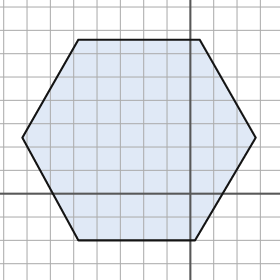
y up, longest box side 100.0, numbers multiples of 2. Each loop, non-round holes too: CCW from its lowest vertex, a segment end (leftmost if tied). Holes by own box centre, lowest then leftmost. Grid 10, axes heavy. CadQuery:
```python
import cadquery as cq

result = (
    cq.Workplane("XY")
    .moveTo(-48.0, -20.0)
    .lineTo(2.0, -20.0)
    .lineTo(28.0, 24.0)
    .lineTo(4.0, 66.0)
    .lineTo(-48.0, 66.0)
    .lineTo(-72.0, 24.0)
    .close()
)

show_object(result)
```